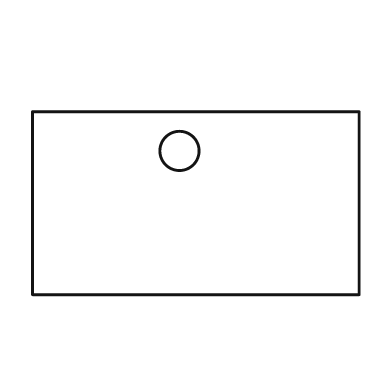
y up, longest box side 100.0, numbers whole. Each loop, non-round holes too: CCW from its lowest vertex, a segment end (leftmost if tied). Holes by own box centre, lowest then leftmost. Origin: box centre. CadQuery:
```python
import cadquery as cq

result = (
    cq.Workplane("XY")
    .moveTo(-50.0, -28.0)
    .lineTo(50.0, -28.0)
    .lineTo(50.0, 28.0)
    .lineTo(-50.0, 28.0)
    .close()
    .moveTo(-5.0, 16.0)
    .circle(6.0)
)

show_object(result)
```